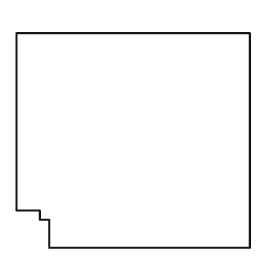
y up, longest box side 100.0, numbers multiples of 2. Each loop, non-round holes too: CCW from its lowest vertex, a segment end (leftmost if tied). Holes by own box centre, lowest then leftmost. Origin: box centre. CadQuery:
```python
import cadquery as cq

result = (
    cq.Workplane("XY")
    .moveTo(-36.0, -46.0)
    .lineTo(50.0, -46.0)
    .lineTo(50.0, 46.0)
    .lineTo(-50.0, 46.0)
    .lineTo(-50.0, -30.0)
    .lineTo(-40.0, -30.0)
    .lineTo(-40.0, -34.0)
    .lineTo(-36.0, -34.0)
    .close()
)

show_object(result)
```